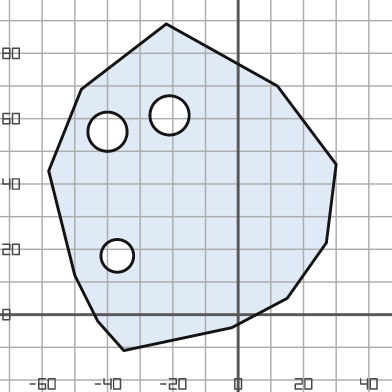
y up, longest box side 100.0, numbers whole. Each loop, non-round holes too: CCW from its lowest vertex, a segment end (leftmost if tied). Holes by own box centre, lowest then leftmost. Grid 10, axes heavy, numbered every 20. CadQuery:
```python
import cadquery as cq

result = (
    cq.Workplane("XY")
    .moveTo(-35.0, -11.0)
    .lineTo(-2.0, -4.0)
    .lineTo(15.0, 5.0)
    .lineTo(27.0, 22.0)
    .lineTo(30.0, 46.0)
    .lineTo(12.0, 70.0)
    .lineTo(-22.0, 89.0)
    .lineTo(-48.0, 69.0)
    .lineTo(-58.0, 44.0)
    .lineTo(-50.0, 12.0)
    .lineTo(-43.0, -2.0)
    .close()
    .moveTo(-37.0, 18.0)
    .circle(5.0)
    .moveTo(-40.0, 56.0)
    .circle(6.0)
    .moveTo(-21.0, 61.0)
    .circle(6.0)
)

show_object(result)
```